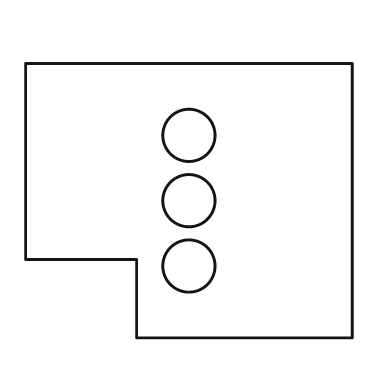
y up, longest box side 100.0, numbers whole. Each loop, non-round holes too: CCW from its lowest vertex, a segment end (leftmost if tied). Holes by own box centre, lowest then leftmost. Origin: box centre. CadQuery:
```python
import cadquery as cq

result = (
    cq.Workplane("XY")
    .moveTo(-16.0, -42.0)
    .lineTo(50.0, -42.0)
    .lineTo(50.0, 42.0)
    .lineTo(-50.0, 42.0)
    .lineTo(-50.0, -18.0)
    .lineTo(-16.0, -18.0)
    .close()
    .moveTo(0.0, -20.0)
    .circle(8.0)
    .moveTo(0.0, 0.0)
    .circle(8.0)
    .moveTo(0.0, 20.0)
    .circle(8.0)
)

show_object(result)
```